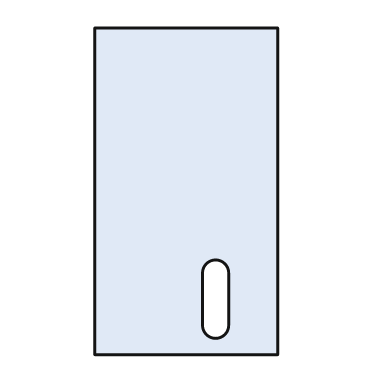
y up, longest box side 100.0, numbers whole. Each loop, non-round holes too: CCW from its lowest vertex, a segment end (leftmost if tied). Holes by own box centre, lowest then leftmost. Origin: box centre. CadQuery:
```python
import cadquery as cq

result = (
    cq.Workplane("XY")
    .moveTo(-28.0, -50.0)
    .lineTo(28.0, -50.0)
    .lineTo(28.0, 50.0)
    .lineTo(-28.0, 50.0)
    .close()
    .moveTo(5.0, -41.0)
    .threePointArc((9.0, -45.0), (13.0, -41.0))
    .lineTo(13.0, -25.0)
    .threePointArc((9.0, -21.0), (5.0, -25.0))
    .close()
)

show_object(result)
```